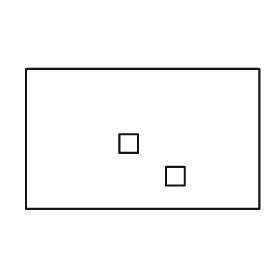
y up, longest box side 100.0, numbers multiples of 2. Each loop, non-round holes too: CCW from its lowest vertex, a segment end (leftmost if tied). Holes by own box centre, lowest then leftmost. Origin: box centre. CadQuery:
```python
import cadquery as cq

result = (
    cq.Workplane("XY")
    .moveTo(-50.0, -30.0)
    .lineTo(50.0, -30.0)
    .lineTo(50.0, 30.0)
    .lineTo(-50.0, 30.0)
    .close()
    .moveTo(10.0, -20.0)
    .lineTo(18.0, -20.0)
    .lineTo(18.0, -12.0)
    .lineTo(10.0, -12.0)
    .close()
    .moveTo(-10.0, -6.0)
    .lineTo(-2.0, -6.0)
    .lineTo(-2.0, 2.0)
    .lineTo(-10.0, 2.0)
    .close()
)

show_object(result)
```